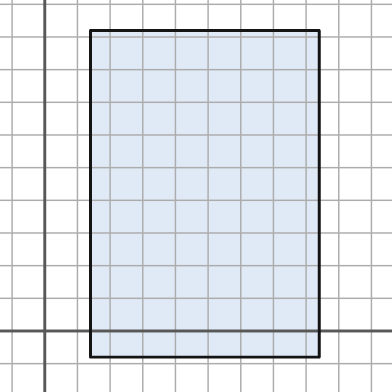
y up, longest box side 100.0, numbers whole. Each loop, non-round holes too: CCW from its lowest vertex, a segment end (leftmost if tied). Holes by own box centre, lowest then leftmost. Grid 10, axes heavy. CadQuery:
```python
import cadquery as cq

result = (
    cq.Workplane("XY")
    .moveTo(14.0, -8.0)
    .lineTo(84.0, -8.0)
    .lineTo(84.0, 92.0)
    .lineTo(14.0, 92.0)
    .close()
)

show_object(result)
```